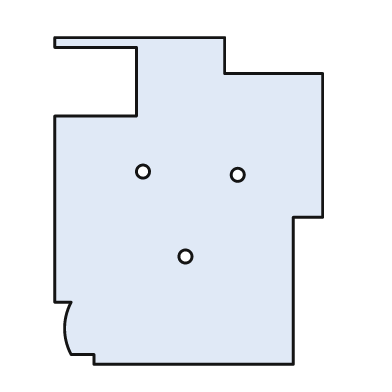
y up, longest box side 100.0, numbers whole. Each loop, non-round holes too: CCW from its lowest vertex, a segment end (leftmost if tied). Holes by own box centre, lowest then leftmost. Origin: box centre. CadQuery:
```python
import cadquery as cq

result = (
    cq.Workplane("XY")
    .moveTo(-29.0, -50.0)
    .lineTo(32.0, -50.0)
    .lineTo(32.0, -5.0)
    .lineTo(41.0, -5.0)
    .lineTo(41.0, 39.0)
    .lineTo(11.0, 39.0)
    .lineTo(11.0, 50.0)
    .lineTo(-41.0, 50.0)
    .lineTo(-41.0, 47.0)
    .lineTo(-16.0, 47.0)
    .lineTo(-16.0, 26.0)
    .lineTo(-41.0, 26.0)
    .lineTo(-41.0, -31.0)
    .lineTo(-36.0, -31.0)
    .threePointArc((-38.0, -39.0), (-36.0, -47.0))
    .lineTo(-29.0, -47.0)
    .close()
    .moveTo(-1.0, -17.0)
    .circle(2.0)
    .moveTo(15.0, 8.0)
    .circle(2.0)
    .moveTo(-14.0, 9.0)
    .circle(2.0)
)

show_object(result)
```